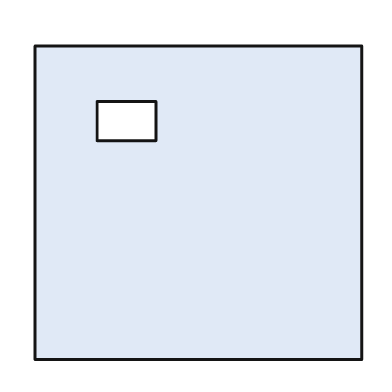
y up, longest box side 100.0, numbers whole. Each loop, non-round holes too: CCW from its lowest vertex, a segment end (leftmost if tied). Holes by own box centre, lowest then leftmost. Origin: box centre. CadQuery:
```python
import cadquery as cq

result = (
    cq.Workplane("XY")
    .moveTo(-50.0, -48.0)
    .lineTo(50.0, -48.0)
    .lineTo(50.0, 48.0)
    .lineTo(-50.0, 48.0)
    .close()
    .moveTo(-31.0, 19.0)
    .lineTo(-13.0, 19.0)
    .lineTo(-13.0, 31.0)
    .lineTo(-31.0, 31.0)
    .close()
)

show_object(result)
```